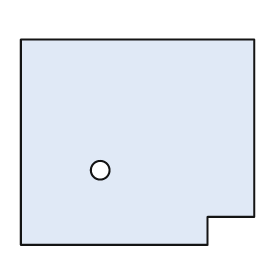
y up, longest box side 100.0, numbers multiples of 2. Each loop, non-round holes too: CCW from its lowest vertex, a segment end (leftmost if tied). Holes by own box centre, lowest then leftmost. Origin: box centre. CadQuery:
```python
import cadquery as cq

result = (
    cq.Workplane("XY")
    .moveTo(-50.0, -44.0)
    .lineTo(30.0, -44.0)
    .lineTo(30.0, -32.0)
    .lineTo(50.0, -32.0)
    .lineTo(50.0, 44.0)
    .lineTo(-50.0, 44.0)
    .close()
    .moveTo(-16.0, -12.0)
    .circle(4.0)
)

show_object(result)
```